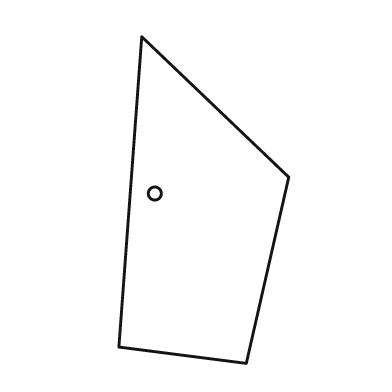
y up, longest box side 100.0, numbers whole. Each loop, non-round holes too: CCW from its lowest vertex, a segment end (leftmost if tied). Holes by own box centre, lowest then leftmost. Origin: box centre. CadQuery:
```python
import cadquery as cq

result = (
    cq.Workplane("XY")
    .moveTo(13.0, -50.0)
    .lineTo(26.0, 7.0)
    .lineTo(-19.0, 50.0)
    .lineTo(-26.0, -45.0)
    .close()
    .moveTo(-15.0, 2.0)
    .circle(2.0)
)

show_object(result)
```